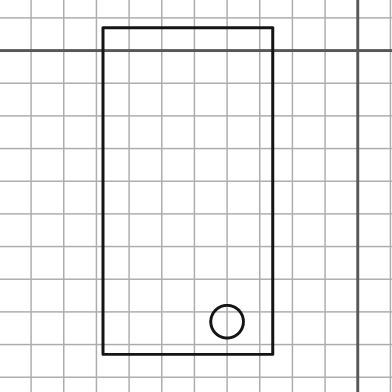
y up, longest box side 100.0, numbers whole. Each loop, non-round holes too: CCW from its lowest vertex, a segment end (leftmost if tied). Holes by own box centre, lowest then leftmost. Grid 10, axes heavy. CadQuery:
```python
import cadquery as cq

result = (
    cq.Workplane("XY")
    .moveTo(-78.0, -93.0)
    .lineTo(-26.0, -93.0)
    .lineTo(-26.0, 7.0)
    .lineTo(-78.0, 7.0)
    .close()
    .moveTo(-40.0, -83.0)
    .circle(5.0)
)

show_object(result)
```